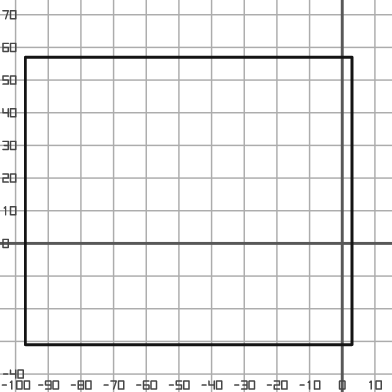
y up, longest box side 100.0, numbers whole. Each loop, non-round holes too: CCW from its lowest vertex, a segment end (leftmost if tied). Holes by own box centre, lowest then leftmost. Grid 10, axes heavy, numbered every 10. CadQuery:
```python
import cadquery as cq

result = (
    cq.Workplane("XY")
    .moveTo(-97.0, -31.0)
    .lineTo(3.0, -31.0)
    .lineTo(3.0, 57.0)
    .lineTo(-97.0, 57.0)
    .close()
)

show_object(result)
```